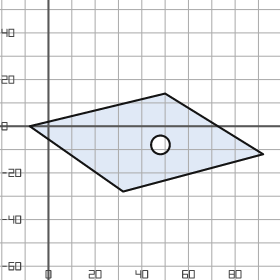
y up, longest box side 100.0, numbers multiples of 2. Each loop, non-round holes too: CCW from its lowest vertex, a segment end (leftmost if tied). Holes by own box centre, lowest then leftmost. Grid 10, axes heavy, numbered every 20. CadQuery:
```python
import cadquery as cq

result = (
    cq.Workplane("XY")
    .moveTo(32.0, -28.0)
    .lineTo(92.0, -12.0)
    .lineTo(50.0, 14.0)
    .lineTo(-8.0, 0.0)
    .close()
    .moveTo(48.0, -8.0)
    .circle(4.0)
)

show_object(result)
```